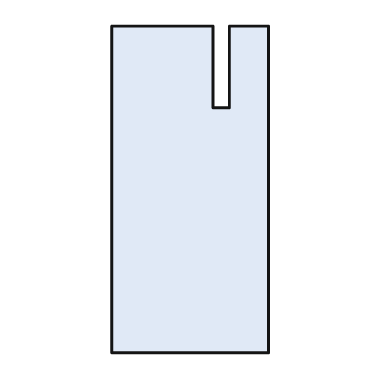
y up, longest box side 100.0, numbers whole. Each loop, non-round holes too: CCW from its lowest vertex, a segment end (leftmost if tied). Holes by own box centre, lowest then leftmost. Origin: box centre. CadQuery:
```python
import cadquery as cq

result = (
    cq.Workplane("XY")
    .moveTo(-24.0, -50.0)
    .lineTo(24.0, -50.0)
    .lineTo(24.0, 50.0)
    .lineTo(12.0, 50.0)
    .lineTo(12.0, 25.0)
    .lineTo(7.0, 25.0)
    .lineTo(7.0, 50.0)
    .lineTo(-24.0, 50.0)
    .close()
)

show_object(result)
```